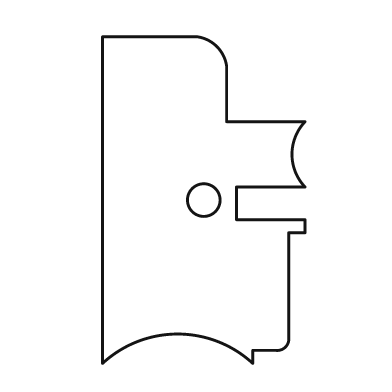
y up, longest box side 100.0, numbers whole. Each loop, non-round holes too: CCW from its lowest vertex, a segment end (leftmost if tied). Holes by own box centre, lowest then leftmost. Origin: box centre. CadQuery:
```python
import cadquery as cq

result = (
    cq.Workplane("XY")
    .moveTo(-31.0, -50.0)
    .threePointArc((-8.0, -41.0), (15.0, -50.0))
    .lineTo(15.0, -46.0)
    .lineTo(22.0, -46.0)
    .threePointArc((25.0, -45.0), (26.0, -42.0))
    .lineTo(26.0, -10.0)
    .lineTo(31.0, -10.0)
    .lineTo(31.0, -6.0)
    .lineTo(10.0, -6.0)
    .lineTo(10.0, 4.0)
    .lineTo(31.0, 4.0)
    .threePointArc((27.0, 14.0), (31.0, 24.0))
    .lineTo(7.0, 24.0)
    .lineTo(7.0, 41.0)
    .threePointArc((4.0, 47.0), (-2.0, 50.0))
    .lineTo(-31.0, 50.0)
    .close()
    .moveTo(0.0, 0.0)
    .circle(5.0)
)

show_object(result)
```